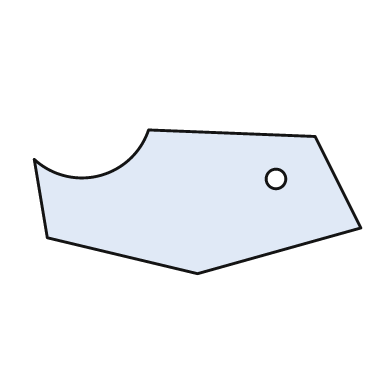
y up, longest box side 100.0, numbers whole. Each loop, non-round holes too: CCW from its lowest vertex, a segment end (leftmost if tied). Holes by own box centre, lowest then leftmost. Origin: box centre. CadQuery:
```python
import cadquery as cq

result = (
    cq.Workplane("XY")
    .moveTo(0.0, -22.0)
    .lineTo(50.0, -8.0)
    .lineTo(36.0, 20.0)
    .lineTo(-15.0, 22.0)
    .threePointArc((-30.0, 8.0), (-50.0, 13.0))
    .lineTo(-46.0, -11.0)
    .close()
    .moveTo(24.0, 7.0)
    .circle(3.0)
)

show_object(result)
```